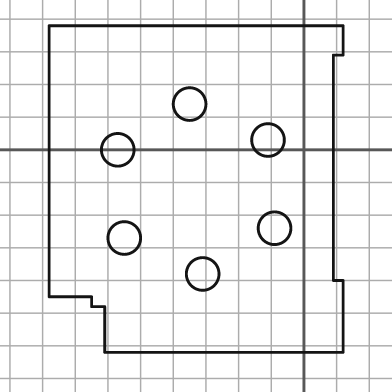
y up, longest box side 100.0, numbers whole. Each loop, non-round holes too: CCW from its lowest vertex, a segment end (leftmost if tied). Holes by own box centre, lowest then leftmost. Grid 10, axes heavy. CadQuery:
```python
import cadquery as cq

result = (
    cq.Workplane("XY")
    .moveTo(-61.0, -62.0)
    .lineTo(12.0, -62.0)
    .lineTo(12.0, -40.0)
    .lineTo(9.0, -40.0)
    .lineTo(9.0, 29.0)
    .lineTo(12.0, 29.0)
    .lineTo(12.0, 38.0)
    .lineTo(-78.0, 38.0)
    .lineTo(-78.0, -45.0)
    .lineTo(-65.0, -45.0)
    .lineTo(-65.0, -48.0)
    .lineTo(-61.0, -48.0)
    .close()
    .moveTo(-31.0, -38.0)
    .circle(5.0)
    .moveTo(-55.0, -27.0)
    .circle(5.0)
    .moveTo(-9.0, -24.0)
    .circle(5.0)
    .moveTo(-57.0, 0.0)
    .circle(5.0)
    .moveTo(-11.0, 3.0)
    .circle(5.0)
    .moveTo(-35.0, 14.0)
    .circle(5.0)
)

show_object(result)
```